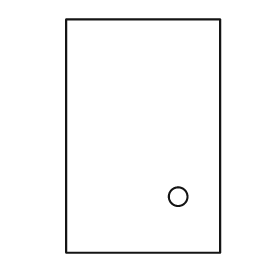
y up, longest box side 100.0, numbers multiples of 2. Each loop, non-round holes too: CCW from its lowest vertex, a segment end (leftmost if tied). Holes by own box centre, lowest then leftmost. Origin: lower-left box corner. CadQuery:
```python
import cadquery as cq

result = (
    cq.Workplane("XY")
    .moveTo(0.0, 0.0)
    .lineTo(66.0, 0.0)
    .lineTo(66.0, 100.0)
    .lineTo(0.0, 100.0)
    .close()
    .moveTo(48.0, 24.0)
    .circle(4.0)
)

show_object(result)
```